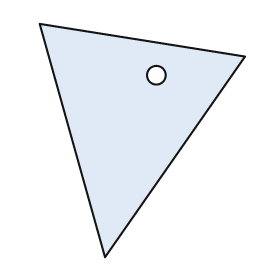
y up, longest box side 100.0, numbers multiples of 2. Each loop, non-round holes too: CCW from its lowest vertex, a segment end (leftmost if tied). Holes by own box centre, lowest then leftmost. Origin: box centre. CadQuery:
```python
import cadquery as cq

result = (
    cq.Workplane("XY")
    .moveTo(-16.0, -50.0)
    .lineTo(44.0, 36.0)
    .lineTo(-44.0, 50.0)
    .close()
    .moveTo(6.0, 28.0)
    .circle(4.0)
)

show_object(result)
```